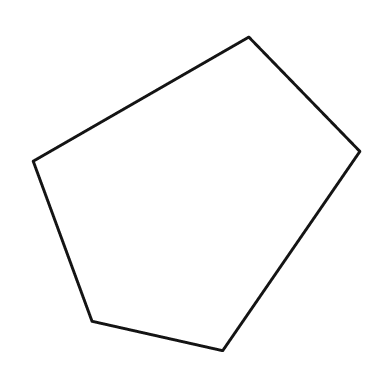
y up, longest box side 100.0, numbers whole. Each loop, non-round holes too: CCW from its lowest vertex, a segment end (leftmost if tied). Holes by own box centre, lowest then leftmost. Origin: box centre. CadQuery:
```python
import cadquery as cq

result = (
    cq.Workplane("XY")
    .moveTo(8.0, -48.0)
    .lineTo(50.0, 13.0)
    .lineTo(16.0, 48.0)
    .lineTo(-50.0, 10.0)
    .lineTo(-32.0, -39.0)
    .close()
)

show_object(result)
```